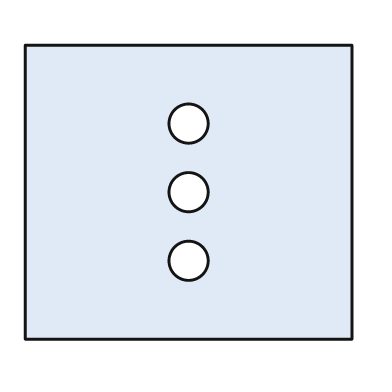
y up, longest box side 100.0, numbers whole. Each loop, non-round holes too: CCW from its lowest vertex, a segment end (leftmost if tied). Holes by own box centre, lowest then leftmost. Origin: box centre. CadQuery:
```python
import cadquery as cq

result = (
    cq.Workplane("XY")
    .moveTo(-50.0, -45.0)
    .lineTo(50.0, -45.0)
    .lineTo(50.0, 45.0)
    .lineTo(-50.0, 45.0)
    .close()
    .moveTo(0.0, -21.0)
    .circle(6.0)
    .moveTo(0.0, 0.0)
    .circle(6.0)
    .moveTo(0.0, 21.0)
    .circle(6.0)
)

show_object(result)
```